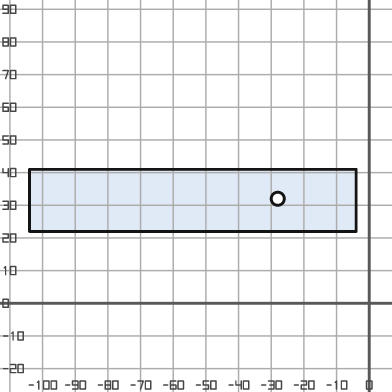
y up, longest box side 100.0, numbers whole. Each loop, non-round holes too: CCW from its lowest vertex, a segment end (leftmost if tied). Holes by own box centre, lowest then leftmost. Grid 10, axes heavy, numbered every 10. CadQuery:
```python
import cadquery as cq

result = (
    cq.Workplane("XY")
    .moveTo(-104.0, 22.0)
    .lineTo(-4.0, 22.0)
    .lineTo(-4.0, 41.0)
    .lineTo(-104.0, 41.0)
    .close()
    .moveTo(-28.0, 32.0)
    .circle(2.0)
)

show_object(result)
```